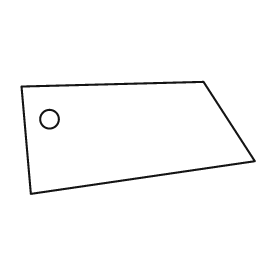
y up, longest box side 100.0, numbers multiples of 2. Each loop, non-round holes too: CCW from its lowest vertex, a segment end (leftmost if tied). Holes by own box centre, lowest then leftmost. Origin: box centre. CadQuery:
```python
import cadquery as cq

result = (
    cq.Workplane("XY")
    .moveTo(-46.0, -24.0)
    .lineTo(50.0, -10.0)
    .lineTo(28.0, 24.0)
    .lineTo(-50.0, 22.0)
    .close()
    .moveTo(-38.0, 8.0)
    .circle(4.0)
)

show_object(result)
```